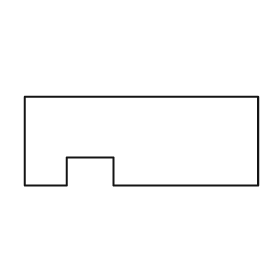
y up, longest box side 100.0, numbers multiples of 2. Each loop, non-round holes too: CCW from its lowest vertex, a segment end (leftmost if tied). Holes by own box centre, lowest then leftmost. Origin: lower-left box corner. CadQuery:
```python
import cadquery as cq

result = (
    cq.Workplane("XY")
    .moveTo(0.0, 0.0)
    .lineTo(18.0, 0.0)
    .lineTo(18.0, 12.0)
    .lineTo(38.0, 12.0)
    .lineTo(38.0, 0.0)
    .lineTo(100.0, 0.0)
    .lineTo(100.0, 38.0)
    .lineTo(0.0, 38.0)
    .close()
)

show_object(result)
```